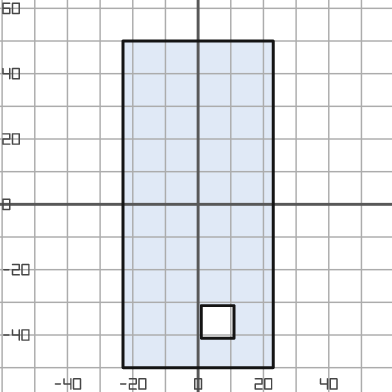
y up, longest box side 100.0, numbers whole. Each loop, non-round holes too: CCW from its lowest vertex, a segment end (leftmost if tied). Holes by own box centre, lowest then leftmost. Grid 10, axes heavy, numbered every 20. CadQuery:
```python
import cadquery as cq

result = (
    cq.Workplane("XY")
    .moveTo(-23.0, -50.0)
    .lineTo(23.0, -50.0)
    .lineTo(23.0, 50.0)
    .lineTo(-23.0, 50.0)
    .close()
    .moveTo(1.0, -41.0)
    .lineTo(11.0, -41.0)
    .lineTo(11.0, -31.0)
    .lineTo(1.0, -31.0)
    .close()
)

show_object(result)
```